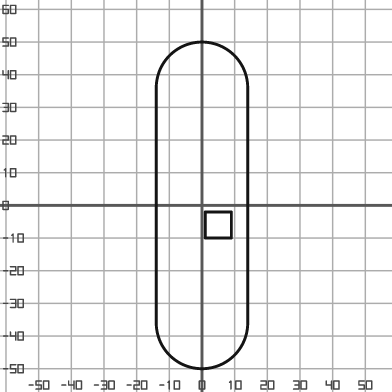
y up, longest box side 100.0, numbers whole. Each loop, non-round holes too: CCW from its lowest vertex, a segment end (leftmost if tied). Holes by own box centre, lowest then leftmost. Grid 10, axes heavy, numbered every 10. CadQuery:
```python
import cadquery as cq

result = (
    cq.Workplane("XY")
    .moveTo(-14.0, -36.0)
    .threePointArc((0.0, -50.0), (14.0, -36.0))
    .lineTo(14.0, 36.0)
    .threePointArc((0.0, 50.0), (-14.0, 36.0))
    .close()
    .moveTo(1.0, -10.0)
    .lineTo(9.0, -10.0)
    .lineTo(9.0, -2.0)
    .lineTo(1.0, -2.0)
    .close()
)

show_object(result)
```